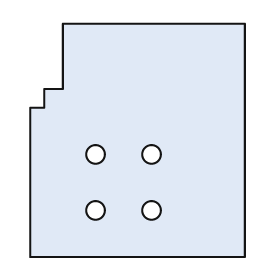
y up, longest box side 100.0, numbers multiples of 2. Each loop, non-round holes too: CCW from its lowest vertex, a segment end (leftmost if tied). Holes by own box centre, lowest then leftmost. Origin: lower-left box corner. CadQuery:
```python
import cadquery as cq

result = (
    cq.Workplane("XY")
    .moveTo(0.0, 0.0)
    .lineTo(92.0, 0.0)
    .lineTo(92.0, 100.0)
    .lineTo(14.0, 100.0)
    .lineTo(14.0, 72.0)
    .lineTo(6.0, 72.0)
    .lineTo(6.0, 64.0)
    .lineTo(0.0, 64.0)
    .close()
    .moveTo(28.0, 20.0)
    .circle(4.0)
    .moveTo(52.0, 20.0)
    .circle(4.0)
    .moveTo(28.0, 44.0)
    .circle(4.0)
    .moveTo(52.0, 44.0)
    .circle(4.0)
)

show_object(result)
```